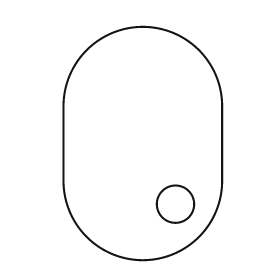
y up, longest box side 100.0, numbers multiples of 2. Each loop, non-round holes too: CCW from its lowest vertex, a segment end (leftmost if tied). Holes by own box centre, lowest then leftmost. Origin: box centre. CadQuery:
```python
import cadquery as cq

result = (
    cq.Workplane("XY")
    .moveTo(-34.0, -16.0)
    .threePointArc((0.0, -50.0), (34.0, -16.0))
    .lineTo(34.0, 16.0)
    .threePointArc((0.0, 50.0), (-34.0, 16.0))
    .close()
    .moveTo(14.0, -26.0)
    .circle(8.0)
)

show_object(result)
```